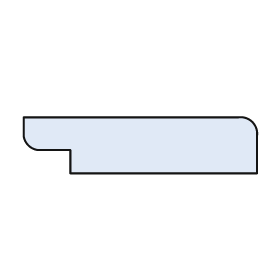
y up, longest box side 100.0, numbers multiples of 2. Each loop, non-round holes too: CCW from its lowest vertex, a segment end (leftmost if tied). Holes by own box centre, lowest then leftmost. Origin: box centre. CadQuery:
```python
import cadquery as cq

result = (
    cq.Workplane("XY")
    .moveTo(-30.0, -12.0)
    .lineTo(50.0, -12.0)
    .lineTo(50.0, 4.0)
    .threePointArc((48.0, 10.0), (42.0, 12.0))
    .lineTo(-50.0, 12.0)
    .lineTo(-50.0, 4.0)
    .threePointArc((-48.0, 0.0), (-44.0, -2.0))
    .lineTo(-30.0, -2.0)
    .close()
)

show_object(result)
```